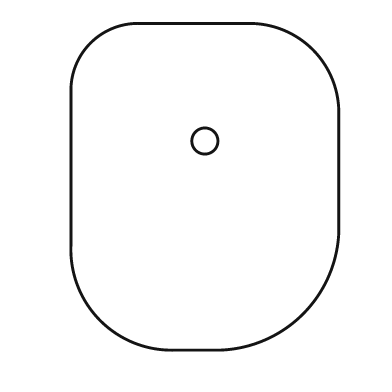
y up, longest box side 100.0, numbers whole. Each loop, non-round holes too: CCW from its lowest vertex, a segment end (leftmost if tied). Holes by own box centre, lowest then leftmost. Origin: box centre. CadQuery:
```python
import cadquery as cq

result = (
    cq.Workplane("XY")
    .moveTo(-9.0, -50.0)
    .lineTo(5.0, -50.0)
    .threePointArc((30.0, -39.0), (41.0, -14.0))
    .lineTo(41.0, 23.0)
    .threePointArc((33.0, 42.0), (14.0, 50.0))
    .lineTo(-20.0, 50.0)
    .threePointArc((-35.0, 44.0), (-41.0, 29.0))
    .lineTo(-41.0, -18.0)
    .threePointArc((-32.0, -41.0), (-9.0, -50.0))
    .close()
    .moveTo(0.0, 14.0)
    .circle(4.0)
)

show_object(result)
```